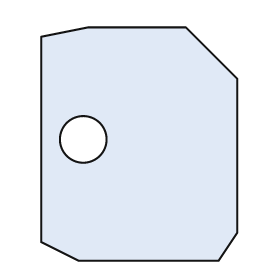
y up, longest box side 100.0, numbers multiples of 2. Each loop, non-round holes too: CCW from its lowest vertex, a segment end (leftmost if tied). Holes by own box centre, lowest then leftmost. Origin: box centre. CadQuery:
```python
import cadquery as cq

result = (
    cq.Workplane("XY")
    .moveTo(-26.0, -50.0)
    .lineTo(34.0, -50.0)
    .lineTo(42.0, -38.0)
    .lineTo(42.0, 28.0)
    .lineTo(20.0, 50.0)
    .lineTo(-22.0, 50.0)
    .lineTo(-42.0, 46.0)
    .lineTo(-42.0, -42.0)
    .close()
    .moveTo(-24.0, 2.0)
    .circle(10.0)
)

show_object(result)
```